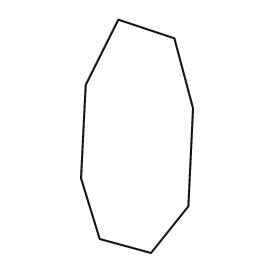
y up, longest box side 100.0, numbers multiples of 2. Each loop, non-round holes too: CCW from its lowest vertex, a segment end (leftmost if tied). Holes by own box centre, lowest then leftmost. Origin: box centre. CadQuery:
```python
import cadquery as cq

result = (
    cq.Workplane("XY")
    .moveTo(6.0, -50.0)
    .lineTo(22.0, -30.0)
    .lineTo(24.0, 12.0)
    .lineTo(16.0, 42.0)
    .lineTo(-8.0, 50.0)
    .lineTo(-22.0, 22.0)
    .lineTo(-24.0, -18.0)
    .lineTo(-16.0, -44.0)
    .close()
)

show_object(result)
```